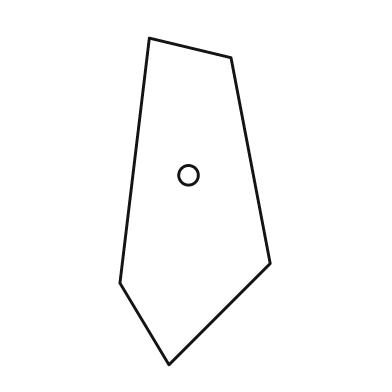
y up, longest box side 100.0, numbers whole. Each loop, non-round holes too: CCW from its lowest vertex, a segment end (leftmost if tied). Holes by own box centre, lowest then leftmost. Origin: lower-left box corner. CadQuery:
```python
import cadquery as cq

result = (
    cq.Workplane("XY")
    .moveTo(15.0, 0.0)
    .lineTo(46.0, 31.0)
    .lineTo(34.0, 94.0)
    .lineTo(9.0, 100.0)
    .lineTo(0.0, 25.0)
    .close()
    .moveTo(21.0, 58.0)
    .circle(3.0)
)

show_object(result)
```